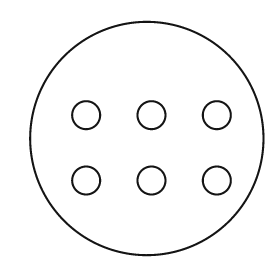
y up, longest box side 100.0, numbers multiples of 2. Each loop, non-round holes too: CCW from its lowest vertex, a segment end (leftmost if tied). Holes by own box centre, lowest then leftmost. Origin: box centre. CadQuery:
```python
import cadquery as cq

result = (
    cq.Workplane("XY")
    .moveTo(0.0, 0.0)
    .circle(50.0)
    .moveTo(-26.0, -18.0)
    .circle(6.0)
    .moveTo(2.0, -18.0)
    .circle(6.0)
    .moveTo(30.0, -18.0)
    .circle(6.0)
    .moveTo(-26.0, 10.0)
    .circle(6.0)
    .moveTo(2.0, 10.0)
    .circle(6.0)
    .moveTo(30.0, 10.0)
    .circle(6.0)
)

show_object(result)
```